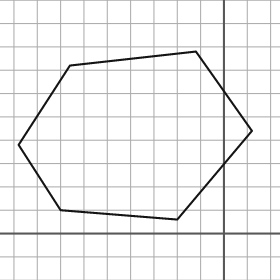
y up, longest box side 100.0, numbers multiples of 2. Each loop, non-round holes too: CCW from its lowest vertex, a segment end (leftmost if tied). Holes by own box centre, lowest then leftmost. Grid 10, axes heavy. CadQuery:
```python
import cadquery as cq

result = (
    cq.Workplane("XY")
    .moveTo(-20.0, 6.0)
    .lineTo(12.0, 44.0)
    .lineTo(-12.0, 78.0)
    .lineTo(-66.0, 72.0)
    .lineTo(-88.0, 38.0)
    .lineTo(-70.0, 10.0)
    .close()
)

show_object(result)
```